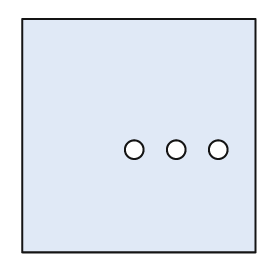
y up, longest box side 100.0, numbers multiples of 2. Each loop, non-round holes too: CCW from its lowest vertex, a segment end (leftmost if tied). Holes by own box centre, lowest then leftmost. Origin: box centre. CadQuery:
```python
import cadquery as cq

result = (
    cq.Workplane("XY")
    .moveTo(-50.0, -50.0)
    .lineTo(50.0, -50.0)
    .lineTo(50.0, 50.0)
    .lineTo(-50.0, 50.0)
    .close()
    .moveTo(-2.0, -6.0)
    .circle(4.0)
    .moveTo(16.0, -6.0)
    .circle(4.0)
    .moveTo(34.0, -6.0)
    .circle(4.0)
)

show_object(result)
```